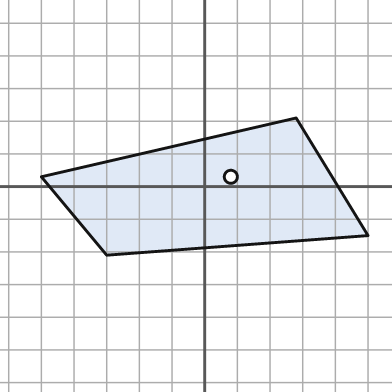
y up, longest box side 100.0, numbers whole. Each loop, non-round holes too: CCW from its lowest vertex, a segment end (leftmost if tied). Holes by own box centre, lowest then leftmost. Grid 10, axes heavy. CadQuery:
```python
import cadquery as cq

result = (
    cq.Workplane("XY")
    .moveTo(-30.0, -21.0)
    .lineTo(50.0, -15.0)
    .lineTo(28.0, 21.0)
    .lineTo(-50.0, 3.0)
    .close()
    .moveTo(8.0, 3.0)
    .circle(2.0)
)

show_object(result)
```